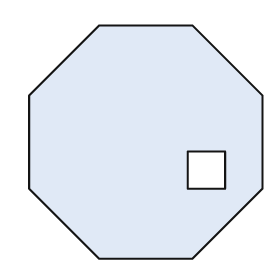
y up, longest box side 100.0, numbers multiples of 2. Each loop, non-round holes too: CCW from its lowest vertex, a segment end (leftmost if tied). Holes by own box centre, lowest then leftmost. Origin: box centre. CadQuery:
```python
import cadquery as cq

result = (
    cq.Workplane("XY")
    .moveTo(-20.0, -50.0)
    .lineTo(20.0, -50.0)
    .lineTo(50.0, -20.0)
    .lineTo(50.0, 20.0)
    .lineTo(20.0, 50.0)
    .lineTo(-20.0, 50.0)
    .lineTo(-50.0, 20.0)
    .lineTo(-50.0, -20.0)
    .close()
    .moveTo(18.0, -20.0)
    .lineTo(34.0, -20.0)
    .lineTo(34.0, -4.0)
    .lineTo(18.0, -4.0)
    .close()
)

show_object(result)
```